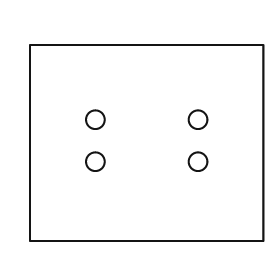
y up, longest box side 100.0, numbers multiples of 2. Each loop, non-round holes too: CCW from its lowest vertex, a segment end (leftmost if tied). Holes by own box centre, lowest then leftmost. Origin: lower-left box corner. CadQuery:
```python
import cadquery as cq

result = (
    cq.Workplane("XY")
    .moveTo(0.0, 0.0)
    .lineTo(100.0, 0.0)
    .lineTo(100.0, 84.0)
    .lineTo(0.0, 84.0)
    .close()
    .moveTo(28.0, 34.0)
    .circle(4.0)
    .moveTo(72.0, 34.0)
    .circle(4.0)
    .moveTo(28.0, 52.0)
    .circle(4.0)
    .moveTo(72.0, 52.0)
    .circle(4.0)
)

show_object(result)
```